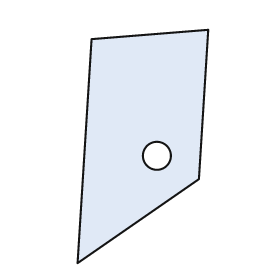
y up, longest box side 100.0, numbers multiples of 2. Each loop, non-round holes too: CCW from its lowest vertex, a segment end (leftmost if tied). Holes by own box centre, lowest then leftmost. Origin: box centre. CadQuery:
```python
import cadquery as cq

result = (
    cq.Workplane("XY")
    .moveTo(-28.0, -50.0)
    .lineTo(24.0, -14.0)
    .lineTo(28.0, 50.0)
    .lineTo(-22.0, 46.0)
    .close()
    .moveTo(6.0, -4.0)
    .circle(6.0)
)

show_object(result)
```